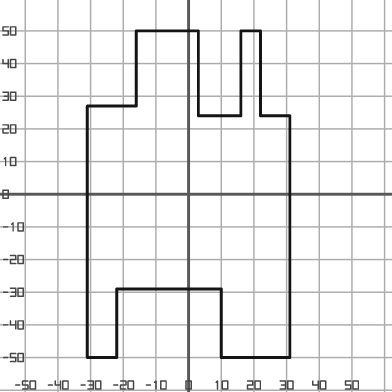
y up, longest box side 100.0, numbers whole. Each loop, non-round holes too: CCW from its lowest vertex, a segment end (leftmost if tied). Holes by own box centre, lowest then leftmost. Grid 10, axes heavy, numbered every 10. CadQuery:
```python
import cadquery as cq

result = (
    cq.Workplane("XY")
    .moveTo(-31.0, -50.0)
    .lineTo(-22.0, -50.0)
    .lineTo(-22.0, -29.0)
    .lineTo(10.0, -29.0)
    .lineTo(10.0, -50.0)
    .lineTo(31.0, -50.0)
    .lineTo(31.0, 24.0)
    .lineTo(22.0, 24.0)
    .lineTo(22.0, 50.0)
    .lineTo(16.0, 50.0)
    .lineTo(16.0, 24.0)
    .lineTo(3.0, 24.0)
    .lineTo(3.0, 50.0)
    .lineTo(-16.0, 50.0)
    .lineTo(-16.0, 27.0)
    .lineTo(-31.0, 27.0)
    .close()
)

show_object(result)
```